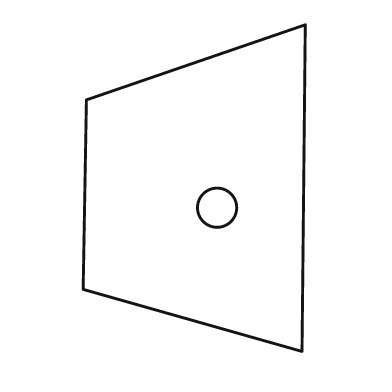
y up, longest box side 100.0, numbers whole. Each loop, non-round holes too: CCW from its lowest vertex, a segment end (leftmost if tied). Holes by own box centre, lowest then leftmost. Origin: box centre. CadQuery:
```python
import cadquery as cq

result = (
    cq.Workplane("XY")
    .moveTo(33.0, -50.0)
    .lineTo(34.0, 50.0)
    .lineTo(-33.0, 27.0)
    .lineTo(-34.0, -31.0)
    .close()
    .moveTo(7.0, -6.0)
    .circle(6.0)
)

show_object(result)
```